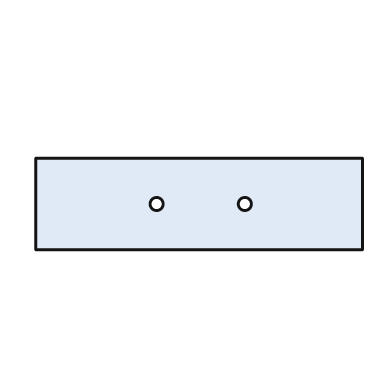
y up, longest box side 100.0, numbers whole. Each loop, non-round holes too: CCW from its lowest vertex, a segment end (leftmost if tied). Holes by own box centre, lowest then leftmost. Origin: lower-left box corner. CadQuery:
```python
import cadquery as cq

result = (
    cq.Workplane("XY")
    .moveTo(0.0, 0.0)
    .lineTo(100.0, 0.0)
    .lineTo(100.0, 28.0)
    .lineTo(0.0, 28.0)
    .close()
    .moveTo(37.0, 14.0)
    .circle(2.0)
    .moveTo(64.0, 14.0)
    .circle(2.0)
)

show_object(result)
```